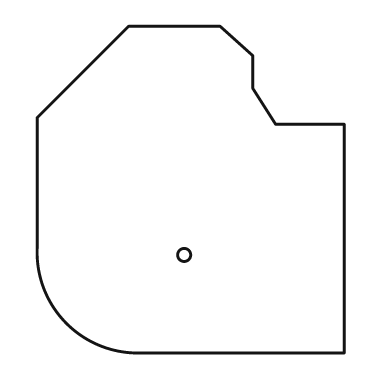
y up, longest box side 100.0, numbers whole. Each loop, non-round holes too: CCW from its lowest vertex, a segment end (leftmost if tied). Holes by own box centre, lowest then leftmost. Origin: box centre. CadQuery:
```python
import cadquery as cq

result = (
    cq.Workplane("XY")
    .moveTo(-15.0, -50.0)
    .lineTo(47.0, -50.0)
    .lineTo(47.0, 20.0)
    .lineTo(26.0, 20.0)
    .lineTo(19.0, 31.0)
    .lineTo(19.0, 41.0)
    .lineTo(9.0, 50.0)
    .lineTo(-19.0, 50.0)
    .lineTo(-47.0, 22.0)
    .lineTo(-47.0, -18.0)
    .threePointArc((-38.0, -41.0), (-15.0, -50.0))
    .close()
    .moveTo(-2.0, -20.0)
    .circle(2.0)
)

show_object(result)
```